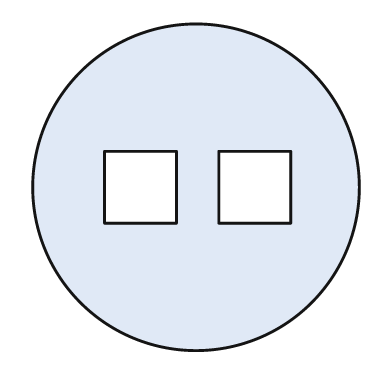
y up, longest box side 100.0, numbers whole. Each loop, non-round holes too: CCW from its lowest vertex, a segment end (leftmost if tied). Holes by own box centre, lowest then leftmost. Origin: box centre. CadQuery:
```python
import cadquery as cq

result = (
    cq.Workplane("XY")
    .moveTo(0.0, 0.0)
    .circle(50.0)
    .moveTo(-28.0, -11.0)
    .lineTo(-6.0, -11.0)
    .lineTo(-6.0, 11.0)
    .lineTo(-28.0, 11.0)
    .close()
    .moveTo(7.0, -11.0)
    .lineTo(29.0, -11.0)
    .lineTo(29.0, 11.0)
    .lineTo(7.0, 11.0)
    .close()
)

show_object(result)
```